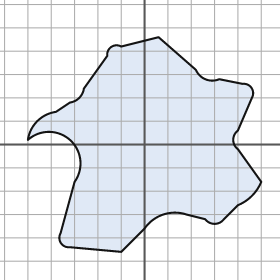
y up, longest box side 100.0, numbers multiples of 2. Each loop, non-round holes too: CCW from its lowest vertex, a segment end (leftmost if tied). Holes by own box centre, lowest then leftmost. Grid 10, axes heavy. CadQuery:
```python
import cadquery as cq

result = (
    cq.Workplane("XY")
    .moveTo(-10.0, -46.0)
    .lineTo(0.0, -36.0)
    .threePointArc((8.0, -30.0), (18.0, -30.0))
    .lineTo(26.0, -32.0)
    .threePointArc((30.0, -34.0), (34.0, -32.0))
    .lineTo(40.0, -26.0)
    .threePointArc((46.0, -22.0), (50.0, -16.0))
    .lineTo(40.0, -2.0)
    .threePointArc((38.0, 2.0), (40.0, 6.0))
    .lineTo(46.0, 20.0)
    .threePointArc((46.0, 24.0), (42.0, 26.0))
    .lineTo(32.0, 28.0)
    .threePointArc((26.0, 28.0), (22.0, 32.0))
    .lineTo(6.0, 46.0)
    .lineTo(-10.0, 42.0)
    .threePointArc((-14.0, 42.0), (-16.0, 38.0))
    .lineTo(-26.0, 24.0)
    .threePointArc((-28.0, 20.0), (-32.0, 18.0))
    .lineTo(-38.0, 14.0)
    .threePointArc((-46.0, 10.0), (-50.0, 2.0))
    .threePointArc((-32.0, 2.0), (-30.0, -16.0))
    .lineTo(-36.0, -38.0)
    .threePointArc((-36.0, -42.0), (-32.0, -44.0))
    .close()
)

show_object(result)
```